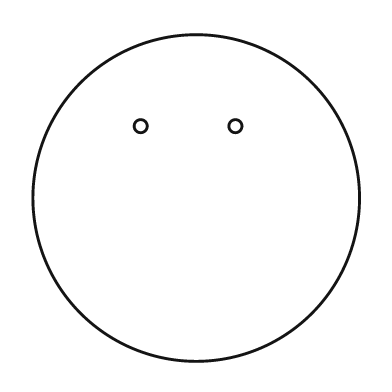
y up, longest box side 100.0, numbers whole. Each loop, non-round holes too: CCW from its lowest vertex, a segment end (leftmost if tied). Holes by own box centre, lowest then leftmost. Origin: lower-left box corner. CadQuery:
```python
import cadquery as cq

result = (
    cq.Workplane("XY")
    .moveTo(50.0, 50.0)
    .circle(50.0)
    .moveTo(33.0, 72.0)
    .circle(2.0)
    .moveTo(62.0, 72.0)
    .circle(2.0)
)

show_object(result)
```